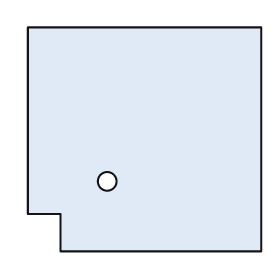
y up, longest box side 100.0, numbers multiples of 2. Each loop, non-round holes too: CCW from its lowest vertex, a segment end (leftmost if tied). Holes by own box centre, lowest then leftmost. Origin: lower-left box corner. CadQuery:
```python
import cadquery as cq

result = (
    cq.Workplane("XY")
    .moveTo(14.0, 0.0)
    .lineTo(100.0, 0.0)
    .lineTo(100.0, 96.0)
    .lineTo(0.0, 96.0)
    .lineTo(0.0, 16.0)
    .lineTo(14.0, 16.0)
    .close()
    .moveTo(34.0, 30.0)
    .circle(4.0)
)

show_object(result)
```